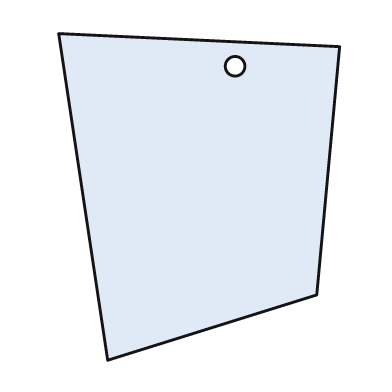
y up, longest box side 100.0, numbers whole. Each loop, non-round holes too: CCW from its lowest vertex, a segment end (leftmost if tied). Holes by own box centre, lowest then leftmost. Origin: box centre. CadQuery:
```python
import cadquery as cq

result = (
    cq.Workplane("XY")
    .moveTo(-28.0, -50.0)
    .lineTo(36.0, -30.0)
    .lineTo(43.0, 46.0)
    .lineTo(-43.0, 50.0)
    .close()
    .moveTo(11.0, 40.0)
    .circle(3.0)
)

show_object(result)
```